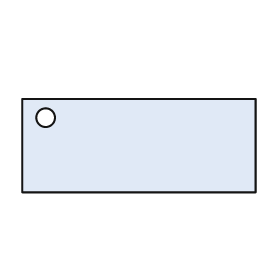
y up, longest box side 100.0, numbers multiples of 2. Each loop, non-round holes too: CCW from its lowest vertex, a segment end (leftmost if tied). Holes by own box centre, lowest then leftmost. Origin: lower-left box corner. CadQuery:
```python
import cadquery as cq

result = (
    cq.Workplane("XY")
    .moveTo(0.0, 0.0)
    .lineTo(100.0, 0.0)
    .lineTo(100.0, 40.0)
    .lineTo(0.0, 40.0)
    .close()
    .moveTo(10.0, 32.0)
    .circle(4.0)
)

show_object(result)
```